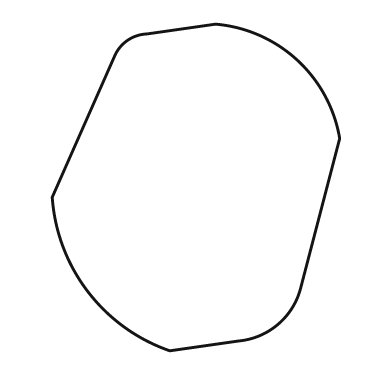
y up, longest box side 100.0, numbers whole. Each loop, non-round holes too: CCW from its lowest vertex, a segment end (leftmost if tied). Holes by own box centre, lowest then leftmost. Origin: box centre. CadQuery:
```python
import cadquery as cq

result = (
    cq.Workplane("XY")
    .moveTo(-8.0, -50.0)
    .lineTo(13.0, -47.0)
    .threePointArc((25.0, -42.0), (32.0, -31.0))
    .lineTo(44.0, 15.0)
    .threePointArc((31.0, 39.0), (6.0, 50.0))
    .lineTo(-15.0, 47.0)
    .threePointArc((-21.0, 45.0), (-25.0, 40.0))
    .lineTo(-44.0, -3.0)
    .threePointArc((-33.0, -32.0), (-8.0, -50.0))
    .close()
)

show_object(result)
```